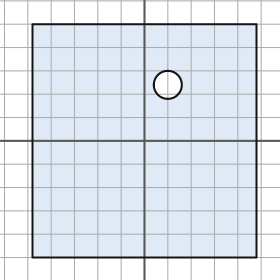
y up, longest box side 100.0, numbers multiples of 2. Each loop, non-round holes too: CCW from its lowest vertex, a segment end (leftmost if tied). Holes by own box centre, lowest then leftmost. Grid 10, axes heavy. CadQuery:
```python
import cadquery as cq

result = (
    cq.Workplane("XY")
    .moveTo(-48.0, -50.0)
    .lineTo(48.0, -50.0)
    .lineTo(48.0, 50.0)
    .lineTo(-48.0, 50.0)
    .close()
    .moveTo(10.0, 24.0)
    .circle(6.0)
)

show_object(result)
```